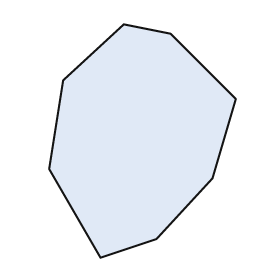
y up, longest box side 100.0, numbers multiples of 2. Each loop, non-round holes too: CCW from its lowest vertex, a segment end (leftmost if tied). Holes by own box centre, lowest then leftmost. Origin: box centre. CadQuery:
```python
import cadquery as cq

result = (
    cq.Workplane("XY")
    .moveTo(-18.0, -50.0)
    .lineTo(6.0, -42.0)
    .lineTo(30.0, -16.0)
    .lineTo(40.0, 18.0)
    .lineTo(12.0, 46.0)
    .lineTo(-8.0, 50.0)
    .lineTo(-34.0, 26.0)
    .lineTo(-40.0, -12.0)
    .close()
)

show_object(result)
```